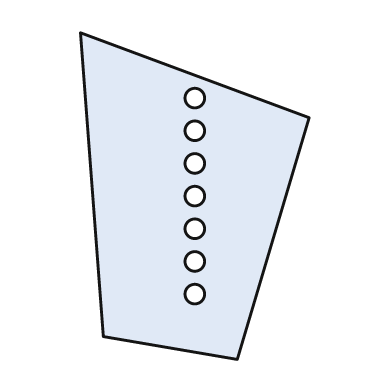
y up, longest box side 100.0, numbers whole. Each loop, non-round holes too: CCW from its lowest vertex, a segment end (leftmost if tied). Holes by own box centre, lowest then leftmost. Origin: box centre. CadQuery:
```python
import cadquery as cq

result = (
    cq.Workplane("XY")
    .moveTo(13.0, -50.0)
    .lineTo(35.0, 24.0)
    .lineTo(-35.0, 50.0)
    .lineTo(-28.0, -43.0)
    .close()
    .moveTo(0.0, -30.0)
    .circle(3.0)
    .moveTo(0.0, -20.0)
    .circle(3.0)
    .moveTo(0.0, -10.0)
    .circle(3.0)
    .moveTo(0.0, 0.0)
    .circle(3.0)
    .moveTo(0.0, 10.0)
    .circle(3.0)
    .moveTo(0.0, 20.0)
    .circle(3.0)
    .moveTo(0.0, 30.0)
    .circle(3.0)
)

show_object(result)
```